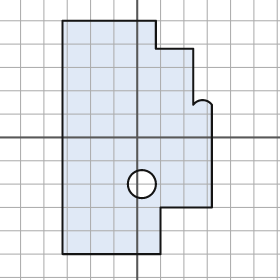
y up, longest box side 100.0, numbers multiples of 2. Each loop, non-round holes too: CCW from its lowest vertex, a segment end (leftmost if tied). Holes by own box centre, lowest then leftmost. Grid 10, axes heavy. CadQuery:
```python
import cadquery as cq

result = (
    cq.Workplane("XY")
    .moveTo(-32.0, -50.0)
    .lineTo(10.0, -50.0)
    .lineTo(10.0, -30.0)
    .lineTo(32.0, -30.0)
    .lineTo(32.0, 14.0)
    .threePointArc((28.0, 16.0), (24.0, 14.0))
    .lineTo(24.0, 38.0)
    .lineTo(8.0, 38.0)
    .lineTo(8.0, 50.0)
    .lineTo(-32.0, 50.0)
    .close()
    .moveTo(2.0, -20.0)
    .circle(6.0)
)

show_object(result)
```